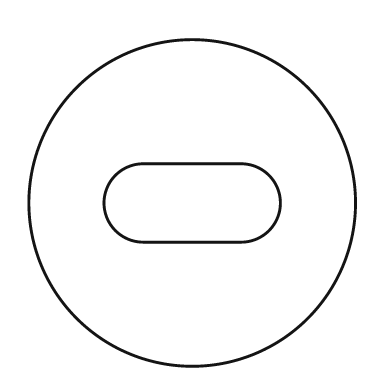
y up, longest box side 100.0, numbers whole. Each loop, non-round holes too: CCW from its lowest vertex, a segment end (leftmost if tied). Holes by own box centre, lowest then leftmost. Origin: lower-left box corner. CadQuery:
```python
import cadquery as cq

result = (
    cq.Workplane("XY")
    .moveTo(50.0, 50.0)
    .circle(50.0)
    .moveTo(35.0, 38.0)
    .lineTo(65.0, 38.0)
    .threePointArc((77.0, 50.0), (65.0, 62.0))
    .lineTo(35.0, 62.0)
    .threePointArc((23.0, 50.0), (35.0, 38.0))
    .close()
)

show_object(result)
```